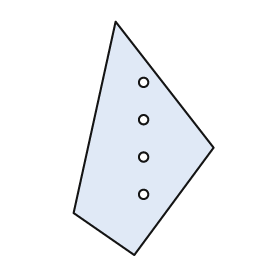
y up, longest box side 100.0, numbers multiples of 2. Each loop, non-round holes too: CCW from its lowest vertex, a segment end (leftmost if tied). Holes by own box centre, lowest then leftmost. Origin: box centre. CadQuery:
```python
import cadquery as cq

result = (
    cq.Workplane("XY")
    .moveTo(-4.0, -50.0)
    .lineTo(30.0, -4.0)
    .lineTo(-12.0, 50.0)
    .lineTo(-30.0, -32.0)
    .close()
    .moveTo(0.0, -24.0)
    .circle(2.0)
    .moveTo(0.0, -8.0)
    .circle(2.0)
    .moveTo(0.0, 8.0)
    .circle(2.0)
    .moveTo(0.0, 24.0)
    .circle(2.0)
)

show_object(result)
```